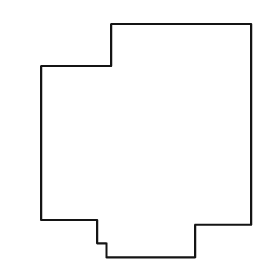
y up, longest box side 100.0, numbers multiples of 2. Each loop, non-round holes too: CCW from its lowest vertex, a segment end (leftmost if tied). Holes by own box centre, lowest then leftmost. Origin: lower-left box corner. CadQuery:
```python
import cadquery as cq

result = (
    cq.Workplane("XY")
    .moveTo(28.0, 0.0)
    .lineTo(66.0, 0.0)
    .lineTo(66.0, 14.0)
    .lineTo(90.0, 14.0)
    .lineTo(90.0, 100.0)
    .lineTo(30.0, 100.0)
    .lineTo(30.0, 82.0)
    .lineTo(0.0, 82.0)
    .lineTo(0.0, 16.0)
    .lineTo(24.0, 16.0)
    .lineTo(24.0, 6.0)
    .lineTo(28.0, 6.0)
    .close()
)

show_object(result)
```